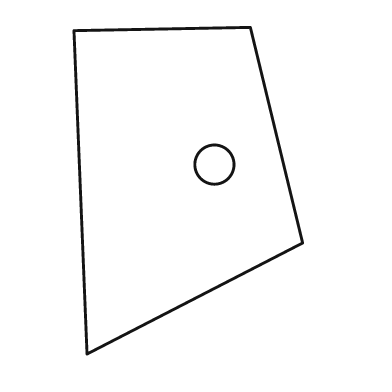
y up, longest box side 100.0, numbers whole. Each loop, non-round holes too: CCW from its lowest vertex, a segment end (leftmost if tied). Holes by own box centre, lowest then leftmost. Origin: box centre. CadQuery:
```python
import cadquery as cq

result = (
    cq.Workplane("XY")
    .moveTo(-31.0, -50.0)
    .lineTo(35.0, -16.0)
    .lineTo(19.0, 50.0)
    .lineTo(-35.0, 49.0)
    .close()
    .moveTo(8.0, 8.0)
    .circle(6.0)
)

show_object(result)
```